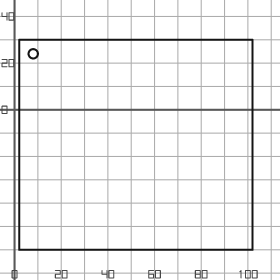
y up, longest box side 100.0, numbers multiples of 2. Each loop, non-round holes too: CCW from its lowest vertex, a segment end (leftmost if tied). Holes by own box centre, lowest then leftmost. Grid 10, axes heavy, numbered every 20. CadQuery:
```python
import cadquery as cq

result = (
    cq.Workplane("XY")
    .moveTo(2.0, -60.0)
    .lineTo(102.0, -60.0)
    .lineTo(102.0, 30.0)
    .lineTo(2.0, 30.0)
    .close()
    .moveTo(8.0, 24.0)
    .circle(2.0)
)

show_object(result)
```